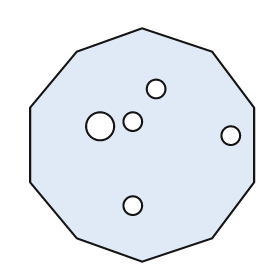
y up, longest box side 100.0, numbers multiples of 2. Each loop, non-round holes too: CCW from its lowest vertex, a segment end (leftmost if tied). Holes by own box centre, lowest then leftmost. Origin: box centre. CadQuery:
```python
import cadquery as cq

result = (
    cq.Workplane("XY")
    .moveTo(0.0, -50.0)
    .lineTo(30.0, -40.0)
    .lineTo(48.0, -16.0)
    .lineTo(48.0, 16.0)
    .lineTo(30.0, 40.0)
    .lineTo(0.0, 50.0)
    .lineTo(-28.0, 40.0)
    .lineTo(-48.0, 16.0)
    .lineTo(-48.0, -16.0)
    .lineTo(-28.0, -40.0)
    .close()
    .moveTo(-4.0, -26.0)
    .circle(4.0)
    .moveTo(38.0, 4.0)
    .circle(4.0)
    .moveTo(-18.0, 8.0)
    .circle(6.0)
    .moveTo(-4.0, 10.0)
    .circle(4.0)
    .moveTo(6.0, 24.0)
    .circle(4.0)
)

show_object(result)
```